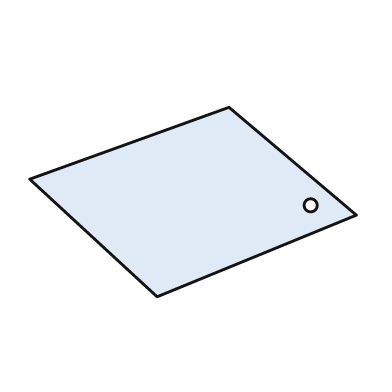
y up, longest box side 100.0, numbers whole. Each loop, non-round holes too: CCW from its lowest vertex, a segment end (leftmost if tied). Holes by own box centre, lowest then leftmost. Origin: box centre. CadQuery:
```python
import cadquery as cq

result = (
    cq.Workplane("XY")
    .moveTo(-11.0, -29.0)
    .lineTo(50.0, -4.0)
    .lineTo(11.0, 29.0)
    .lineTo(-50.0, 7.0)
    .close()
    .moveTo(36.0, -1.0)
    .circle(2.0)
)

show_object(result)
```